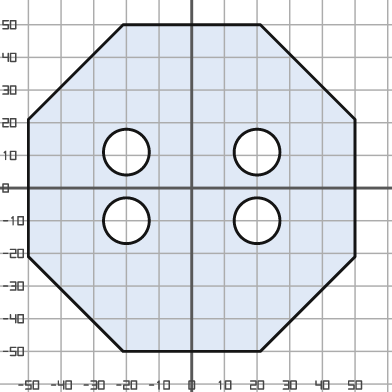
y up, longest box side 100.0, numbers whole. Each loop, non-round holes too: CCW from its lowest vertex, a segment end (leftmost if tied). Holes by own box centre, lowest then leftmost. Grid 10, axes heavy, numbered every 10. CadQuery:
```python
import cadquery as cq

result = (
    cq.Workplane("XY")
    .moveTo(-21.0, -50.0)
    .lineTo(21.0, -50.0)
    .lineTo(50.0, -21.0)
    .lineTo(50.0, 21.0)
    .lineTo(21.0, 50.0)
    .lineTo(-21.0, 50.0)
    .lineTo(-50.0, 21.0)
    .lineTo(-50.0, -21.0)
    .close()
    .moveTo(-20.0, -10.0)
    .circle(7.0)
    .moveTo(20.0, -10.0)
    .circle(7.0)
    .moveTo(-20.0, 11.0)
    .circle(7.0)
    .moveTo(20.0, 11.0)
    .circle(7.0)
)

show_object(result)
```